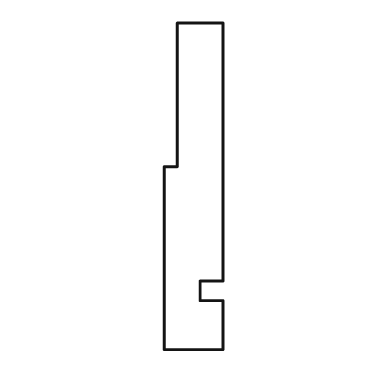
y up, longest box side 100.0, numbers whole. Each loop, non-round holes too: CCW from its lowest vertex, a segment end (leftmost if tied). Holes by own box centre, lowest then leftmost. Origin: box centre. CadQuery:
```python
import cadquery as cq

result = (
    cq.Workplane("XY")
    .moveTo(-9.0, -50.0)
    .lineTo(9.0, -50.0)
    .lineTo(9.0, -35.0)
    .lineTo(2.0, -35.0)
    .lineTo(2.0, -29.0)
    .lineTo(9.0, -29.0)
    .lineTo(9.0, 50.0)
    .lineTo(-5.0, 50.0)
    .lineTo(-5.0, 6.0)
    .lineTo(-9.0, 6.0)
    .close()
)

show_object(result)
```